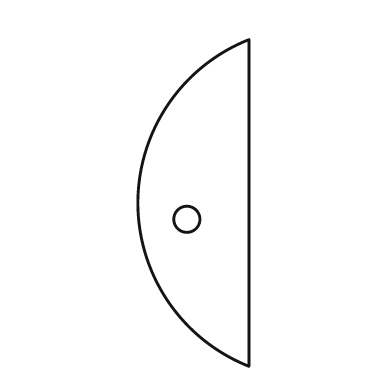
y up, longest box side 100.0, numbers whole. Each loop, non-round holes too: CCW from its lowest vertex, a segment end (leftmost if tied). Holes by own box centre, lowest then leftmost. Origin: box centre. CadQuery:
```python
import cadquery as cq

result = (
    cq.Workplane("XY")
    .moveTo(17.0, -50.0)
    .lineTo(17.0, 50.0)
    .threePointArc((-17.0, 0.0), (17.0, -50.0))
    .close()
    .moveTo(-2.0, -5.0)
    .circle(4.0)
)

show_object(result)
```